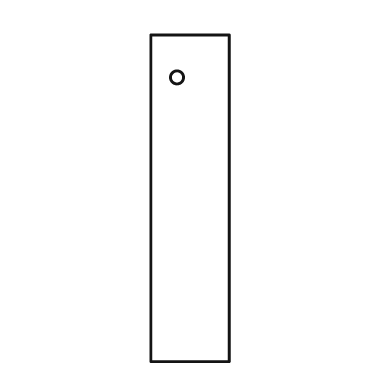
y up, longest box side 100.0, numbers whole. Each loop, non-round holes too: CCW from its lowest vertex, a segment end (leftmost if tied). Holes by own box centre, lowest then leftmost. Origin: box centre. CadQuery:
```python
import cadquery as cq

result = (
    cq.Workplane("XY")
    .moveTo(-12.0, -50.0)
    .lineTo(12.0, -50.0)
    .lineTo(12.0, 50.0)
    .lineTo(-12.0, 50.0)
    .close()
    .moveTo(-4.0, 37.0)
    .circle(2.0)
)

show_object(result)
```